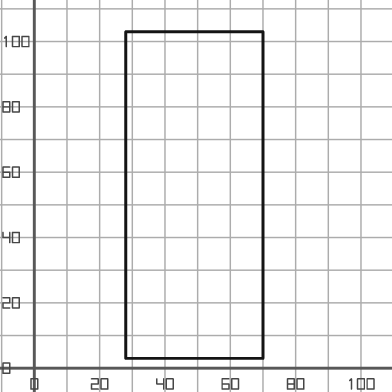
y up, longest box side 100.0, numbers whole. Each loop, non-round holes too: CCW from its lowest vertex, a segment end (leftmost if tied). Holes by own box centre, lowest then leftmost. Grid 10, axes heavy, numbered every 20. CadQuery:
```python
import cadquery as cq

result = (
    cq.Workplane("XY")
    .moveTo(28.0, 3.0)
    .lineTo(70.0, 3.0)
    .lineTo(70.0, 103.0)
    .lineTo(28.0, 103.0)
    .close()
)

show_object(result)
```